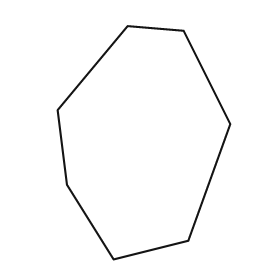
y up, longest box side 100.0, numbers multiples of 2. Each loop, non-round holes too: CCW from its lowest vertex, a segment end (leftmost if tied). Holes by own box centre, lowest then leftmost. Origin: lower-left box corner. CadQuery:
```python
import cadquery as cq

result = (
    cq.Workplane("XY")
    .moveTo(24.0, 0.0)
    .lineTo(56.0, 8.0)
    .lineTo(74.0, 58.0)
    .lineTo(54.0, 98.0)
    .lineTo(30.0, 100.0)
    .lineTo(0.0, 64.0)
    .lineTo(4.0, 32.0)
    .close()
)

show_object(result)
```